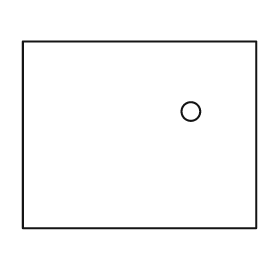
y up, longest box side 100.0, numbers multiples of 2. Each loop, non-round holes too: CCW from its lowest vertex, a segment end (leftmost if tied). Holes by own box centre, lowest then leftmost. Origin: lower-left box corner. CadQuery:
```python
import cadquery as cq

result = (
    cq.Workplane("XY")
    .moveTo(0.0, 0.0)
    .lineTo(100.0, 0.0)
    .lineTo(100.0, 80.0)
    .lineTo(0.0, 80.0)
    .close()
    .moveTo(72.0, 50.0)
    .circle(4.0)
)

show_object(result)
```